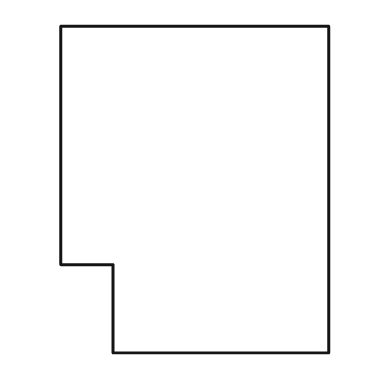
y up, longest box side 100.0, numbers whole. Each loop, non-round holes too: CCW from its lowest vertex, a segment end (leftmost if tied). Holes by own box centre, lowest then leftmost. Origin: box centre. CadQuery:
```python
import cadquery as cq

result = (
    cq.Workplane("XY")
    .moveTo(-25.0, -50.0)
    .lineTo(41.0, -50.0)
    .lineTo(41.0, 50.0)
    .lineTo(-41.0, 50.0)
    .lineTo(-41.0, -23.0)
    .lineTo(-25.0, -23.0)
    .close()
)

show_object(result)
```